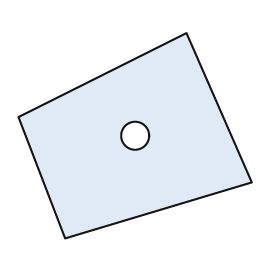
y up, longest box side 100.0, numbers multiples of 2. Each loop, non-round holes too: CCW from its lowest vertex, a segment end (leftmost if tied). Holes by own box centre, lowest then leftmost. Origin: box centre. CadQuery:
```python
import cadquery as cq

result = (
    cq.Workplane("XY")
    .moveTo(-30.0, -44.0)
    .lineTo(50.0, -20.0)
    .lineTo(22.0, 44.0)
    .lineTo(-50.0, 8.0)
    .close()
    .moveTo(0.0, 0.0)
    .circle(6.0)
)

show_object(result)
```